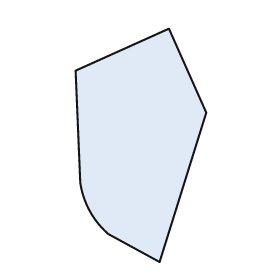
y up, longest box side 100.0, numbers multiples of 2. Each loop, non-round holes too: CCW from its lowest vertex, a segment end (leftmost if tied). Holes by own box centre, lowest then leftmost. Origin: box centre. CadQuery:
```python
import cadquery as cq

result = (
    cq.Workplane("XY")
    .moveTo(8.0, -50.0)
    .lineTo(28.0, 14.0)
    .lineTo(12.0, 50.0)
    .lineTo(-28.0, 32.0)
    .lineTo(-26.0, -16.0)
    .threePointArc((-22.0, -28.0), (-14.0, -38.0))
    .close()
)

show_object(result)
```